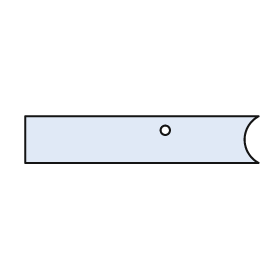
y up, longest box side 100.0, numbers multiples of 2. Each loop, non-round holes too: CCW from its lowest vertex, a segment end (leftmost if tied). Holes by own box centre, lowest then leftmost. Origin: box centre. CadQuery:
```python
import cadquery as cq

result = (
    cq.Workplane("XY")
    .moveTo(-50.0, -10.0)
    .lineTo(50.0, -10.0)
    .threePointArc((44.0, 0.0), (50.0, 10.0))
    .lineTo(-50.0, 10.0)
    .close()
    .moveTo(10.0, 4.0)
    .circle(2.0)
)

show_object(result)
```